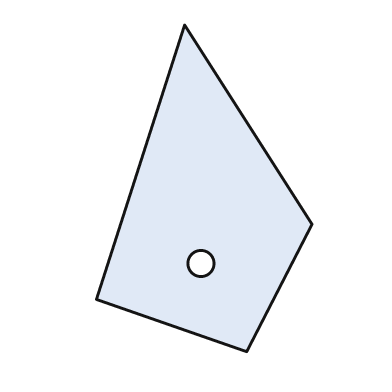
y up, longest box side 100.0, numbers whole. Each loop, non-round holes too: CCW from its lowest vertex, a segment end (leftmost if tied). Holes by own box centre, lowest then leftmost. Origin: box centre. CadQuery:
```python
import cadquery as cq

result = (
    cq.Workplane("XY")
    .moveTo(13.0, -50.0)
    .lineTo(33.0, -11.0)
    .lineTo(-6.0, 50.0)
    .lineTo(-33.0, -34.0)
    .close()
    .moveTo(-1.0, -23.0)
    .circle(4.0)
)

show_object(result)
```